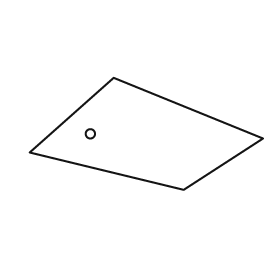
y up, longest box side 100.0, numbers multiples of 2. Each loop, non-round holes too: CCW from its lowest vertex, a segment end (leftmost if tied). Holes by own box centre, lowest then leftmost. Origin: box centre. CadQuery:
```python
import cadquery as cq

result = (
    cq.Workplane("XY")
    .moveTo(16.0, -24.0)
    .lineTo(50.0, -2.0)
    .lineTo(-14.0, 24.0)
    .lineTo(-50.0, -8.0)
    .close()
    .moveTo(-24.0, 0.0)
    .circle(2.0)
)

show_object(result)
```